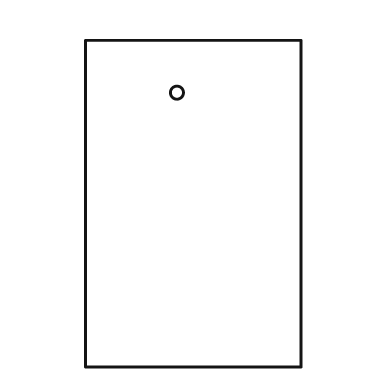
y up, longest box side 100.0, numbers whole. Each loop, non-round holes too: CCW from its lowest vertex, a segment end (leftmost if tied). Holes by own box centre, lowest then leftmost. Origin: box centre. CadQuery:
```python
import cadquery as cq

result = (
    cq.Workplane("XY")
    .moveTo(-33.0, -50.0)
    .lineTo(33.0, -50.0)
    .lineTo(33.0, 50.0)
    .lineTo(-33.0, 50.0)
    .close()
    .moveTo(-5.0, 34.0)
    .circle(2.0)
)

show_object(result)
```